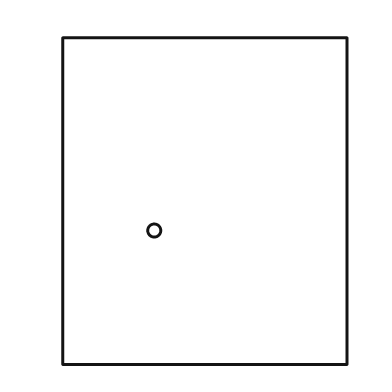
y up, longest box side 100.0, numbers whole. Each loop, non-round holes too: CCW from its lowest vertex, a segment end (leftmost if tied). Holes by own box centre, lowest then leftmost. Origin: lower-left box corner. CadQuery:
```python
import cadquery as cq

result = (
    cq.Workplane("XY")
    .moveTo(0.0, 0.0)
    .lineTo(87.0, 0.0)
    .lineTo(87.0, 100.0)
    .lineTo(0.0, 100.0)
    .close()
    .moveTo(28.0, 41.0)
    .circle(2.0)
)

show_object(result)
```